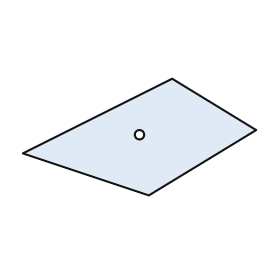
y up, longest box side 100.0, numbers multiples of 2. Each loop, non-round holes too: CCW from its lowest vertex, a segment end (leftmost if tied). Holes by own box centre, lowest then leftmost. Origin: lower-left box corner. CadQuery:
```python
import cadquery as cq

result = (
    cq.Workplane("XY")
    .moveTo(54.0, 0.0)
    .lineTo(100.0, 28.0)
    .lineTo(64.0, 50.0)
    .lineTo(0.0, 18.0)
    .close()
    .moveTo(50.0, 26.0)
    .circle(2.0)
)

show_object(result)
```